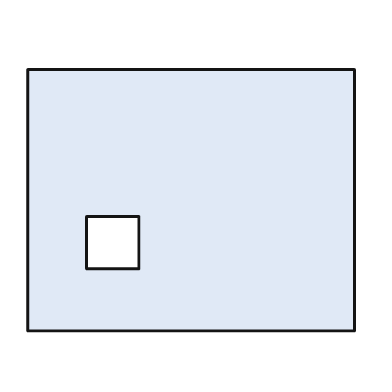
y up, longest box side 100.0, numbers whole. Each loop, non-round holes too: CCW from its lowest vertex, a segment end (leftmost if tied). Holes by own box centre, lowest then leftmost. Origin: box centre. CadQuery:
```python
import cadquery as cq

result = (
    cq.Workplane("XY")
    .moveTo(-50.0, -40.0)
    .lineTo(50.0, -40.0)
    .lineTo(50.0, 40.0)
    .lineTo(-50.0, 40.0)
    .close()
    .moveTo(-32.0, -21.0)
    .lineTo(-16.0, -21.0)
    .lineTo(-16.0, -5.0)
    .lineTo(-32.0, -5.0)
    .close()
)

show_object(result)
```